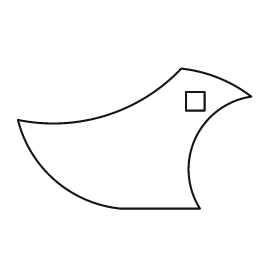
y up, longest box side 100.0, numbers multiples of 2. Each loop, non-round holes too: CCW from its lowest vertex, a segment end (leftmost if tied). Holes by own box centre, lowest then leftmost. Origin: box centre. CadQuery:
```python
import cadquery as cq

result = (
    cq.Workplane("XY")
    .moveTo(-6.0, -30.0)
    .lineTo(28.0, -30.0)
    .threePointArc((26.0, 0.0), (50.0, 18.0))
    .threePointArc((36.0, 26.0), (20.0, 30.0))
    .threePointArc((-12.0, 10.0), (-50.0, 8.0))
    .threePointArc((-34.0, -18.0), (-6.0, -30.0))
    .close()
    .moveTo(22.0, 12.0)
    .lineTo(30.0, 12.0)
    .lineTo(30.0, 20.0)
    .lineTo(22.0, 20.0)
    .close()
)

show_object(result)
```